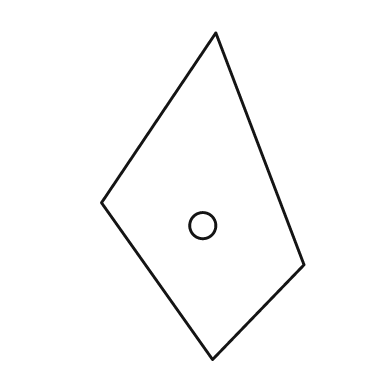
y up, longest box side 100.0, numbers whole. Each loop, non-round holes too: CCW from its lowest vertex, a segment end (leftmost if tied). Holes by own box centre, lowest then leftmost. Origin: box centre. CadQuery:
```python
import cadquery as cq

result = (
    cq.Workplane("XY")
    .moveTo(3.0, -50.0)
    .lineTo(31.0, -21.0)
    .lineTo(4.0, 50.0)
    .lineTo(-31.0, -2.0)
    .close()
    .moveTo(0.0, -9.0)
    .circle(4.0)
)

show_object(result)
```